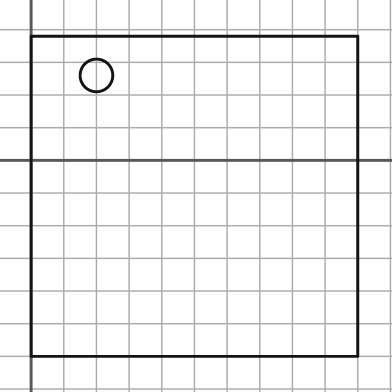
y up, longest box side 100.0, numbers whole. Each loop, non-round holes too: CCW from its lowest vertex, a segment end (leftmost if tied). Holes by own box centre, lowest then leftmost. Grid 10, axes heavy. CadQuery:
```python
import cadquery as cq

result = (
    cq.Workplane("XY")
    .moveTo(0.0, -60.0)
    .lineTo(100.0, -60.0)
    .lineTo(100.0, 38.0)
    .lineTo(0.0, 38.0)
    .close()
    .moveTo(20.0, 26.0)
    .circle(5.0)
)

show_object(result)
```